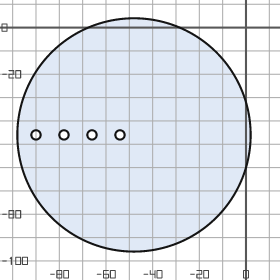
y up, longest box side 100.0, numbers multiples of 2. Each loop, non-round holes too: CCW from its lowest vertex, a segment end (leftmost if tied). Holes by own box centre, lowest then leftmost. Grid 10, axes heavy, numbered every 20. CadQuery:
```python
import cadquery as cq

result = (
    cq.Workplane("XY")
    .moveTo(-48.0, -46.0)
    .circle(50.0)
    .moveTo(-90.0, -46.0)
    .circle(2.0)
    .moveTo(-78.0, -46.0)
    .circle(2.0)
    .moveTo(-66.0, -46.0)
    .circle(2.0)
    .moveTo(-54.0, -46.0)
    .circle(2.0)
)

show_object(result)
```